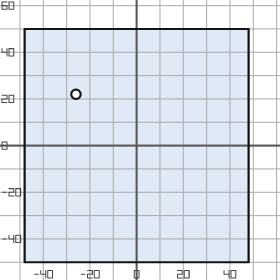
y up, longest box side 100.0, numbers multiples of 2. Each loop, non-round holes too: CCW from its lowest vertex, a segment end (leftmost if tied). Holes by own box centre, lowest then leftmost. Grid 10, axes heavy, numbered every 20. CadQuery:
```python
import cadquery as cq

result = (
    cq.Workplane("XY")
    .moveTo(-48.0, -50.0)
    .lineTo(48.0, -50.0)
    .lineTo(48.0, 50.0)
    .lineTo(-48.0, 50.0)
    .close()
    .moveTo(-26.0, 22.0)
    .circle(2.0)
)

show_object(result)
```